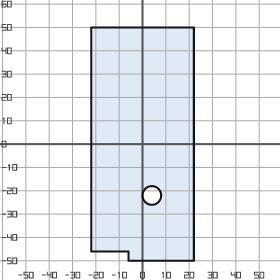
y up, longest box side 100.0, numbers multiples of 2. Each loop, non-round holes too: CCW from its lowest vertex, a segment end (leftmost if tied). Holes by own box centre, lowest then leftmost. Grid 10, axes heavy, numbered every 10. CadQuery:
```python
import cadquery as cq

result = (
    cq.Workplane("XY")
    .moveTo(-6.0, -50.0)
    .lineTo(22.0, -50.0)
    .lineTo(22.0, 50.0)
    .lineTo(-22.0, 50.0)
    .lineTo(-22.0, -46.0)
    .lineTo(-6.0, -46.0)
    .close()
    .moveTo(4.0, -22.0)
    .circle(4.0)
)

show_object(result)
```